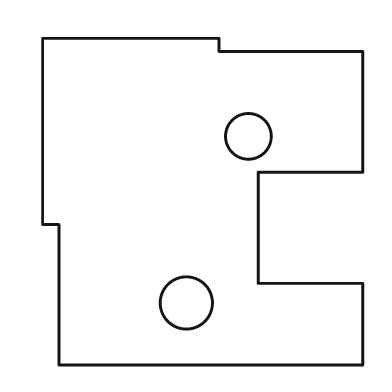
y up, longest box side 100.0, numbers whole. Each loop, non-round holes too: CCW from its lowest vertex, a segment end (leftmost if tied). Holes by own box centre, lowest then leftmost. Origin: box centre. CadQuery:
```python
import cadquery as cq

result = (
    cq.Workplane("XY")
    .moveTo(-44.0, -50.0)
    .lineTo(49.0, -50.0)
    .lineTo(49.0, -25.0)
    .lineTo(17.0, -25.0)
    .lineTo(17.0, 9.0)
    .lineTo(49.0, 9.0)
    .lineTo(49.0, 46.0)
    .lineTo(5.0, 46.0)
    .lineTo(5.0, 50.0)
    .lineTo(-49.0, 50.0)
    .lineTo(-49.0, -7.0)
    .lineTo(-44.0, -7.0)
    .close()
    .moveTo(-5.0, -31.0)
    .circle(8.0)
    .moveTo(14.0, 20.0)
    .circle(7.0)
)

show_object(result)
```